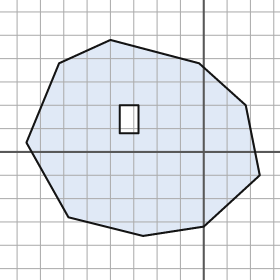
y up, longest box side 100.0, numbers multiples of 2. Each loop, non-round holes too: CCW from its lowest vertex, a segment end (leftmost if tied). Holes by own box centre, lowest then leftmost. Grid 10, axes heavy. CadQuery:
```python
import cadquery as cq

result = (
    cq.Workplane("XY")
    .moveTo(-26.0, -36.0)
    .lineTo(0.0, -32.0)
    .lineTo(24.0, -10.0)
    .lineTo(18.0, 20.0)
    .lineTo(-2.0, 38.0)
    .lineTo(-40.0, 48.0)
    .lineTo(-62.0, 38.0)
    .lineTo(-76.0, 4.0)
    .lineTo(-58.0, -28.0)
    .close()
    .moveTo(-36.0, 8.0)
    .lineTo(-28.0, 8.0)
    .lineTo(-28.0, 20.0)
    .lineTo(-36.0, 20.0)
    .close()
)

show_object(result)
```